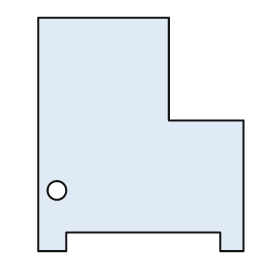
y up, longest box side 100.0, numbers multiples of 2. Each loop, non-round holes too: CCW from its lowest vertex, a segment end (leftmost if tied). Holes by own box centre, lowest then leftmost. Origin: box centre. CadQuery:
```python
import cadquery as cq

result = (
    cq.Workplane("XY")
    .moveTo(-44.0, -50.0)
    .lineTo(-32.0, -50.0)
    .lineTo(-32.0, -42.0)
    .lineTo(34.0, -42.0)
    .lineTo(34.0, -50.0)
    .lineTo(44.0, -50.0)
    .lineTo(44.0, 6.0)
    .lineTo(12.0, 6.0)
    .lineTo(12.0, 50.0)
    .lineTo(-44.0, 50.0)
    .close()
    .moveTo(-36.0, -24.0)
    .circle(4.0)
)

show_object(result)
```